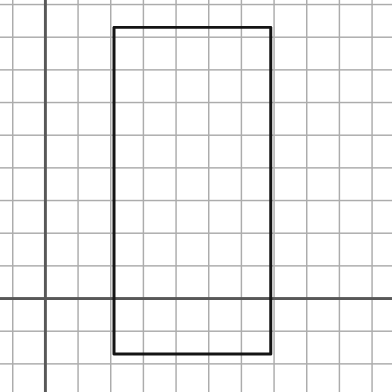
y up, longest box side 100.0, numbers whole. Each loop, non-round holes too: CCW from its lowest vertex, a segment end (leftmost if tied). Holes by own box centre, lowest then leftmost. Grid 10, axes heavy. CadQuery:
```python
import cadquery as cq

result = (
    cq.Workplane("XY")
    .moveTo(21.0, -17.0)
    .lineTo(69.0, -17.0)
    .lineTo(69.0, 83.0)
    .lineTo(21.0, 83.0)
    .close()
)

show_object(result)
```